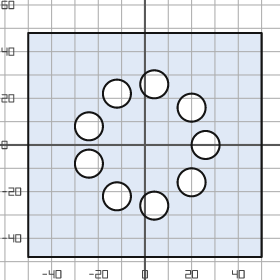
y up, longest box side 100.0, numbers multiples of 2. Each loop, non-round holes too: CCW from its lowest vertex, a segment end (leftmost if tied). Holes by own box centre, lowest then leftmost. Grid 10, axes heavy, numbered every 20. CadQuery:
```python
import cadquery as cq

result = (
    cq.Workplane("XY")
    .moveTo(-50.0, -48.0)
    .lineTo(50.0, -48.0)
    .lineTo(50.0, 48.0)
    .lineTo(-50.0, 48.0)
    .close()
    .moveTo(4.0, -26.0)
    .circle(6.0)
    .moveTo(-12.0, -22.0)
    .circle(6.0)
    .moveTo(20.0, -16.0)
    .circle(6.0)
    .moveTo(-24.0, -8.0)
    .circle(6.0)
    .moveTo(26.0, 0.0)
    .circle(6.0)
    .moveTo(-24.0, 8.0)
    .circle(6.0)
    .moveTo(20.0, 16.0)
    .circle(6.0)
    .moveTo(-12.0, 22.0)
    .circle(6.0)
    .moveTo(4.0, 26.0)
    .circle(6.0)
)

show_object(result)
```